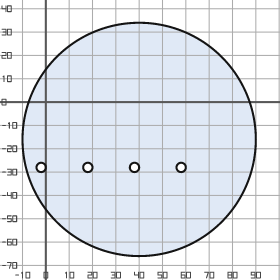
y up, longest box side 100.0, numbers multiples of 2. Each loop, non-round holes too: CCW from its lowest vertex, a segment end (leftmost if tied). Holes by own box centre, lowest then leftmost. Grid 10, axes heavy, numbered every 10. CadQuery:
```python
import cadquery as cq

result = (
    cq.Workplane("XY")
    .moveTo(40.0, -16.0)
    .circle(50.0)
    .moveTo(-2.0, -28.0)
    .circle(2.0)
    .moveTo(18.0, -28.0)
    .circle(2.0)
    .moveTo(38.0, -28.0)
    .circle(2.0)
    .moveTo(58.0, -28.0)
    .circle(2.0)
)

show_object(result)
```